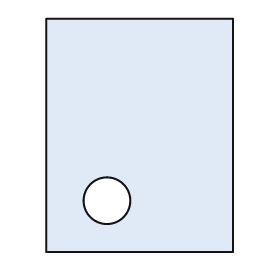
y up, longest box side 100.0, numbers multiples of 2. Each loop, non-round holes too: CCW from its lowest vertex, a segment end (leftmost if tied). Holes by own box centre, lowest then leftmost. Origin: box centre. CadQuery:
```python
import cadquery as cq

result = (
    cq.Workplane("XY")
    .moveTo(-40.0, -50.0)
    .lineTo(40.0, -50.0)
    .lineTo(40.0, 50.0)
    .lineTo(-40.0, 50.0)
    .close()
    .moveTo(-14.0, -28.0)
    .circle(10.0)
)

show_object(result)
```